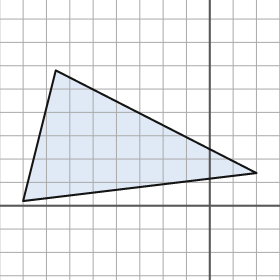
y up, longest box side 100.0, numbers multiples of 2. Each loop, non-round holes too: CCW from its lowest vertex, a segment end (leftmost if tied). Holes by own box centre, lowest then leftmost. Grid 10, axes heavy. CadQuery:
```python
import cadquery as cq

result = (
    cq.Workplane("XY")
    .moveTo(-80.0, 2.0)
    .lineTo(20.0, 14.0)
    .lineTo(-66.0, 58.0)
    .close()
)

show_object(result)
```